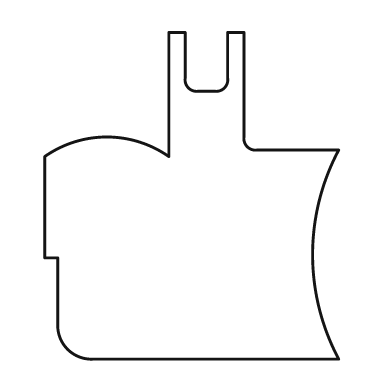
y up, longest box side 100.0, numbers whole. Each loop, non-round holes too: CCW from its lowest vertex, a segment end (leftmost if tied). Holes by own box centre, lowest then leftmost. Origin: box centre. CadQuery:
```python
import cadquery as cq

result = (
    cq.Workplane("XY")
    .moveTo(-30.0, -50.0)
    .lineTo(45.0, -50.0)
    .threePointArc((37.0, -18.0), (45.0, 14.0))
    .lineTo(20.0, 14.0)
    .threePointArc((17.0, 15.0), (16.0, 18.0))
    .lineTo(16.0, 50.0)
    .lineTo(11.0, 50.0)
    .lineTo(11.0, 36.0)
    .threePointArc((10.0, 33.0), (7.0, 32.0))
    .lineTo(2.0, 32.0)
    .threePointArc((-1.0, 33.0), (-2.0, 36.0))
    .lineTo(-2.0, 50.0)
    .lineTo(-7.0, 50.0)
    .lineTo(-7.0, 12.0)
    .threePointArc((-26.0, 18.0), (-45.0, 12.0))
    .lineTo(-45.0, -19.0)
    .lineTo(-41.0, -19.0)
    .lineTo(-41.0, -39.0)
    .threePointArc((-38.0, -47.0), (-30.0, -50.0))
    .close()
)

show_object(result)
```